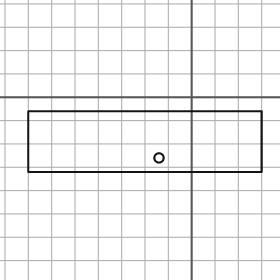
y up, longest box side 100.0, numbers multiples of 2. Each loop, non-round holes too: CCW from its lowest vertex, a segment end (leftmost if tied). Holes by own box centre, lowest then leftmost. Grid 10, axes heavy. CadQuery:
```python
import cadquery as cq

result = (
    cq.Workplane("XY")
    .moveTo(-70.0, -32.0)
    .lineTo(30.0, -32.0)
    .lineTo(30.0, -6.0)
    .lineTo(-70.0, -6.0)
    .close()
    .moveTo(-14.0, -26.0)
    .circle(2.0)
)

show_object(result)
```